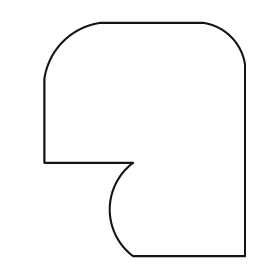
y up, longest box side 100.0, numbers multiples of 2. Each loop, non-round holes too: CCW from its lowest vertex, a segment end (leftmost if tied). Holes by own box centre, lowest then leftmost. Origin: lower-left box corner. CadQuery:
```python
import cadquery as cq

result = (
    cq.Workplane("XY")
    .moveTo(38.0, 0.0)
    .lineTo(86.0, 0.0)
    .lineTo(86.0, 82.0)
    .threePointArc((80.0, 94.0), (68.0, 100.0))
    .lineTo(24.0, 100.0)
    .threePointArc((8.0, 92.0), (0.0, 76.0))
    .lineTo(0.0, 40.0)
    .lineTo(38.0, 40.0)
    .threePointArc((28.0, 20.0), (38.0, 0.0))
    .close()
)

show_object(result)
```